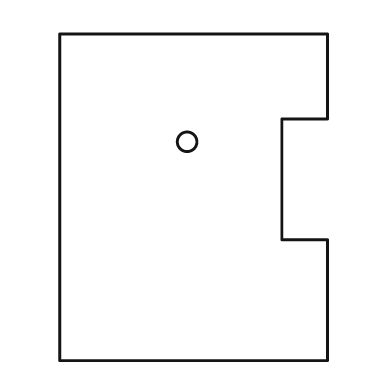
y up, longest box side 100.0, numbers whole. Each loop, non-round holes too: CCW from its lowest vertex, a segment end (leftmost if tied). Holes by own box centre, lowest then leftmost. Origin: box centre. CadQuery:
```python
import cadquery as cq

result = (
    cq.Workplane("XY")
    .moveTo(-41.0, -50.0)
    .lineTo(41.0, -50.0)
    .lineTo(41.0, -13.0)
    .lineTo(27.0, -13.0)
    .lineTo(27.0, 24.0)
    .lineTo(41.0, 24.0)
    .lineTo(41.0, 50.0)
    .lineTo(-41.0, 50.0)
    .close()
    .moveTo(-2.0, 17.0)
    .circle(3.0)
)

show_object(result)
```